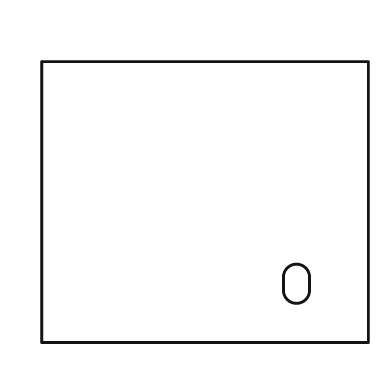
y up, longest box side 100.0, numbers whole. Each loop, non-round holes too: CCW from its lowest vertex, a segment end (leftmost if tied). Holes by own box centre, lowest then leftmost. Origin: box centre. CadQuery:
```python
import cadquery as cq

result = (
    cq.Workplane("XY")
    .moveTo(-50.0, -43.0)
    .lineTo(50.0, -43.0)
    .lineTo(50.0, 43.0)
    .lineTo(-50.0, 43.0)
    .close()
    .moveTo(24.0, -27.0)
    .threePointArc((28.0, -31.0), (32.0, -27.0))
    .lineTo(32.0, -23.0)
    .threePointArc((28.0, -19.0), (24.0, -23.0))
    .close()
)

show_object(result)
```